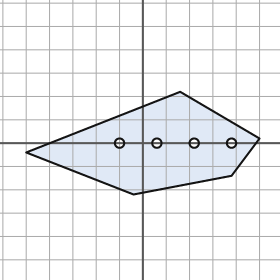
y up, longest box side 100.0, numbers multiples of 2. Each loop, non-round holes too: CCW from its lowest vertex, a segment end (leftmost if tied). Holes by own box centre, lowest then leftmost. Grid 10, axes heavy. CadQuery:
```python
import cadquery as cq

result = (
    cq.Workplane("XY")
    .moveTo(-4.0, -22.0)
    .lineTo(38.0, -14.0)
    .lineTo(50.0, 2.0)
    .lineTo(16.0, 22.0)
    .lineTo(-50.0, -4.0)
    .close()
    .moveTo(-10.0, 0.0)
    .circle(2.0)
    .moveTo(6.0, 0.0)
    .circle(2.0)
    .moveTo(22.0, 0.0)
    .circle(2.0)
    .moveTo(38.0, 0.0)
    .circle(2.0)
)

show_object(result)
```